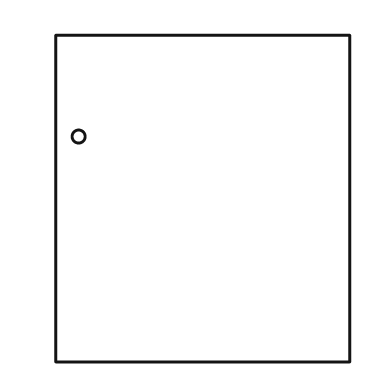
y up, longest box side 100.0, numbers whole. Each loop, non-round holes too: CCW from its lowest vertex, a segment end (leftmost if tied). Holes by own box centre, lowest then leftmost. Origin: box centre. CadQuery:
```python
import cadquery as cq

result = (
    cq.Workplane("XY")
    .moveTo(-45.0, -50.0)
    .lineTo(45.0, -50.0)
    .lineTo(45.0, 50.0)
    .lineTo(-45.0, 50.0)
    .close()
    .moveTo(-38.0, 19.0)
    .circle(2.0)
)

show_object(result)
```